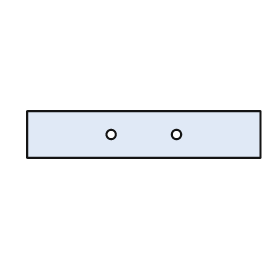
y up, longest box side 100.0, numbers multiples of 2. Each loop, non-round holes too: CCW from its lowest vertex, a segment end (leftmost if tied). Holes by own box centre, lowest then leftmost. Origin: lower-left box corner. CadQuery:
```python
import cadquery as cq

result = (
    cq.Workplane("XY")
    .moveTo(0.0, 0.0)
    .lineTo(100.0, 0.0)
    .lineTo(100.0, 20.0)
    .lineTo(0.0, 20.0)
    .close()
    .moveTo(36.0, 10.0)
    .circle(2.0)
    .moveTo(64.0, 10.0)
    .circle(2.0)
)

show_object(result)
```